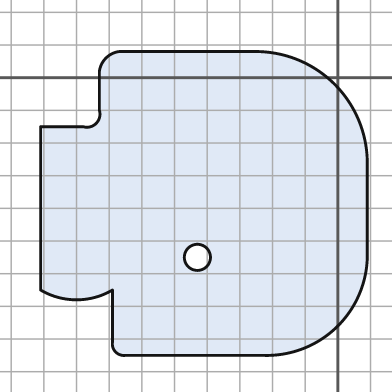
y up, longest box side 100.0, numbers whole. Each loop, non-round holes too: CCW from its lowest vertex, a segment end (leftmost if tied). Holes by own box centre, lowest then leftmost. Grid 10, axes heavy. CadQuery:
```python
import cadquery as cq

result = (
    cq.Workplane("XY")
    .moveTo(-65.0, -85.0)
    .lineTo(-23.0, -85.0)
    .threePointArc((0.0, -76.0), (9.0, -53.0))
    .lineTo(9.0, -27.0)
    .threePointArc((-1.0, -2.0), (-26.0, 8.0))
    .lineTo(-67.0, 8.0)
    .threePointArc((-71.0, 6.0), (-73.0, 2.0))
    .lineTo(-73.0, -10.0)
    .threePointArc((-74.0, -14.0), (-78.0, -15.0))
    .lineTo(-91.0, -15.0)
    .lineTo(-91.0, -65.0)
    .threePointArc((-80.0, -68.0), (-69.0, -65.0))
    .lineTo(-69.0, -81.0)
    .threePointArc((-68.0, -84.0), (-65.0, -85.0))
    .close()
    .moveTo(-43.0, -55.0)
    .circle(4.0)
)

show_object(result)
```